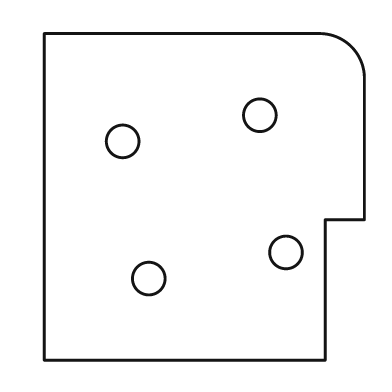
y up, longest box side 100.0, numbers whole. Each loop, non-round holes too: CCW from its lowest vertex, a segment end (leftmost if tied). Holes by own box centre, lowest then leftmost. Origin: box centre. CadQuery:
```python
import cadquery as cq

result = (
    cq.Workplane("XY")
    .moveTo(-49.0, -50.0)
    .lineTo(37.0, -50.0)
    .lineTo(37.0, -7.0)
    .lineTo(49.0, -7.0)
    .lineTo(49.0, 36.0)
    .threePointArc((45.0, 46.0), (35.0, 50.0))
    .lineTo(-49.0, 50.0)
    .close()
    .moveTo(-17.0, -25.0)
    .circle(5.0)
    .moveTo(25.0, -17.0)
    .circle(5.0)
    .moveTo(-25.0, 17.0)
    .circle(5.0)
    .moveTo(17.0, 25.0)
    .circle(5.0)
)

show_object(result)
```